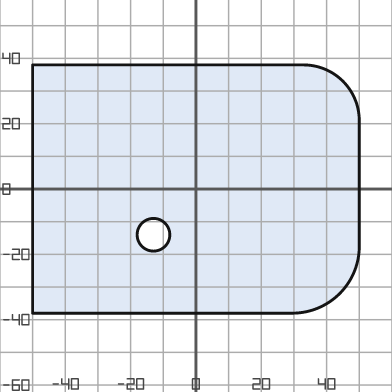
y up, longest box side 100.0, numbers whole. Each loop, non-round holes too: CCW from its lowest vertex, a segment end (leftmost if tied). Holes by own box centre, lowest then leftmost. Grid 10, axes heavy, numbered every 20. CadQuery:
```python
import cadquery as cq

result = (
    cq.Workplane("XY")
    .moveTo(-50.0, -38.0)
    .lineTo(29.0, -38.0)
    .threePointArc((44.0, -32.0), (50.0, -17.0))
    .lineTo(50.0, 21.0)
    .threePointArc((45.0, 33.0), (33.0, 38.0))
    .lineTo(-50.0, 38.0)
    .close()
    .moveTo(-13.0, -14.0)
    .circle(5.0)
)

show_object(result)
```